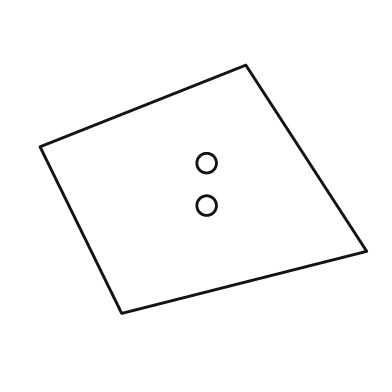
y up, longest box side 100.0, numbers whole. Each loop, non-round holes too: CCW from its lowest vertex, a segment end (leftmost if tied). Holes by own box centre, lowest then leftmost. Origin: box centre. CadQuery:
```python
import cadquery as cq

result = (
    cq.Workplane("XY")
    .moveTo(-25.0, -38.0)
    .lineTo(50.0, -19.0)
    .lineTo(13.0, 38.0)
    .lineTo(-50.0, 13.0)
    .close()
    .moveTo(1.0, -5.0)
    .circle(3.0)
    .moveTo(1.0, 8.0)
    .circle(3.0)
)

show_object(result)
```